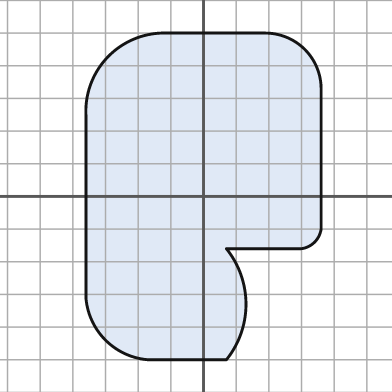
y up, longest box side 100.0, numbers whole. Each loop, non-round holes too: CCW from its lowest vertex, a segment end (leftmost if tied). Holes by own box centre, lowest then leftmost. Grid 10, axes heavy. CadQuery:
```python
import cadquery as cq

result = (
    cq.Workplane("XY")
    .moveTo(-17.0, -50.0)
    .lineTo(7.0, -50.0)
    .threePointArc((13.0, -33.0), (7.0, -16.0))
    .lineTo(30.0, -16.0)
    .threePointArc((34.0, -14.0), (36.0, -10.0))
    .lineTo(36.0, 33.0)
    .threePointArc((31.0, 45.0), (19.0, 50.0))
    .lineTo(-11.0, 50.0)
    .threePointArc((-29.0, 43.0), (-36.0, 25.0))
    .lineTo(-36.0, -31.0)
    .threePointArc((-30.0, -44.0), (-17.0, -50.0))
    .close()
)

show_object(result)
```